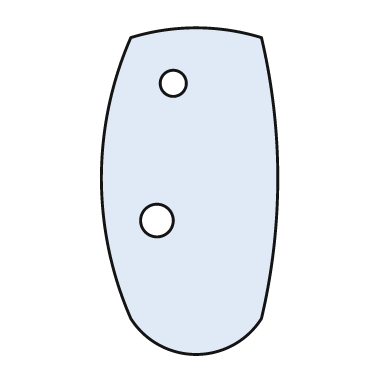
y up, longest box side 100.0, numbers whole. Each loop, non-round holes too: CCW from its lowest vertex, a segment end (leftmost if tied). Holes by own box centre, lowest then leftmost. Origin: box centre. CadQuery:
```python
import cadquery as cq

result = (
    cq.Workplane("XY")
    .moveTo(-18.0, -39.0)
    .threePointArc((2.0, -50.0), (22.0, -39.0))
    .threePointArc((27.0, 4.0), (22.0, 47.0))
    .threePointArc((2.0, 50.0), (-18.0, 47.0))
    .threePointArc((-27.0, 4.0), (-18.0, -39.0))
    .close()
    .moveTo(-10.0, -9.0)
    .circle(5.0)
    .moveTo(-5.0, 33.0)
    .circle(4.0)
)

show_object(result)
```